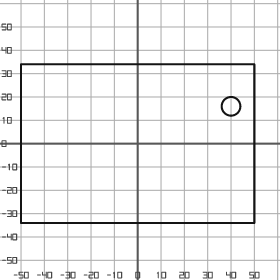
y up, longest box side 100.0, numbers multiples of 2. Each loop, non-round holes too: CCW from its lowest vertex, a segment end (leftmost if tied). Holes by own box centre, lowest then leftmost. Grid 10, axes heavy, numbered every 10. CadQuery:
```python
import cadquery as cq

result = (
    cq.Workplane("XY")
    .moveTo(-50.0, -34.0)
    .lineTo(50.0, -34.0)
    .lineTo(50.0, 34.0)
    .lineTo(-50.0, 34.0)
    .close()
    .moveTo(40.0, 16.0)
    .circle(4.0)
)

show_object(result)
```